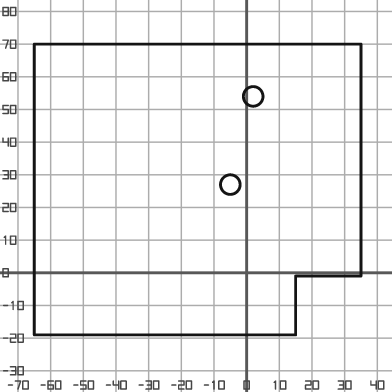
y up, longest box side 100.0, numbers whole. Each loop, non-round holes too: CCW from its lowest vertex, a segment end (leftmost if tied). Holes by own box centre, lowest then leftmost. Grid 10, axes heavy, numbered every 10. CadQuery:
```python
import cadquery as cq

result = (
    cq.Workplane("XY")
    .moveTo(-65.0, -19.0)
    .lineTo(15.0, -19.0)
    .lineTo(15.0, -1.0)
    .lineTo(35.0, -1.0)
    .lineTo(35.0, 70.0)
    .lineTo(-65.0, 70.0)
    .close()
    .moveTo(-5.0, 27.0)
    .circle(3.0)
    .moveTo(2.0, 54.0)
    .circle(3.0)
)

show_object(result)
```